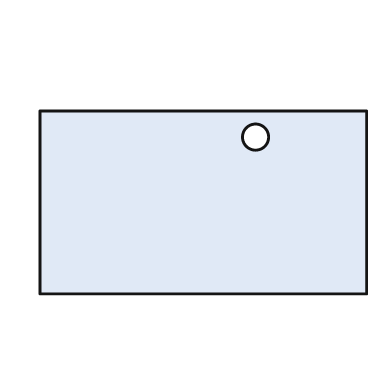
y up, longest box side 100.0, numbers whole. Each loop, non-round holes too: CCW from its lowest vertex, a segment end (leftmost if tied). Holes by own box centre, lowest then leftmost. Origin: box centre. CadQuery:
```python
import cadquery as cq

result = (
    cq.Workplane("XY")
    .moveTo(-50.0, -28.0)
    .lineTo(50.0, -28.0)
    .lineTo(50.0, 28.0)
    .lineTo(-50.0, 28.0)
    .close()
    .moveTo(16.0, 20.0)
    .circle(4.0)
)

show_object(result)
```